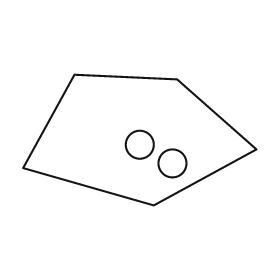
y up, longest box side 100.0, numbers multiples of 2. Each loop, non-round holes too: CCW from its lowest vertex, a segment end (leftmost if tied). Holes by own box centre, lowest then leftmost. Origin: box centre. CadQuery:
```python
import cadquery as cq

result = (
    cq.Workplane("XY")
    .moveTo(6.0, -28.0)
    .lineTo(50.0, -4.0)
    .lineTo(16.0, 26.0)
    .lineTo(-28.0, 28.0)
    .lineTo(-50.0, -12.0)
    .close()
    .moveTo(14.0, -10.0)
    .circle(6.0)
    .moveTo(0.0, -2.0)
    .circle(6.0)
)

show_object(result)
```